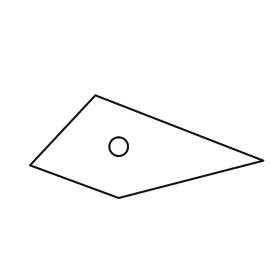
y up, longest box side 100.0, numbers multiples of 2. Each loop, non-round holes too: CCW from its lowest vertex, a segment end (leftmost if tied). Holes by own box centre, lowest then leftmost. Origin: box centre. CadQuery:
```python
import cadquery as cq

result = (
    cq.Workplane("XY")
    .moveTo(-12.0, -22.0)
    .lineTo(50.0, -6.0)
    .lineTo(-22.0, 22.0)
    .lineTo(-50.0, -8.0)
    .close()
    .moveTo(-12.0, 0.0)
    .circle(4.0)
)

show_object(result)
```